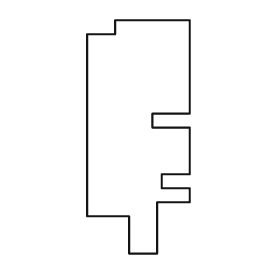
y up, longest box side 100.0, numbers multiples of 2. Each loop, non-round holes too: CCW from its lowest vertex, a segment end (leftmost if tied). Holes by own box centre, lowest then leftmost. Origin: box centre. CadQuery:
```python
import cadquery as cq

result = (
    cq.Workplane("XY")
    .moveTo(-4.0, -50.0)
    .lineTo(8.0, -50.0)
    .lineTo(8.0, -28.0)
    .lineTo(22.0, -28.0)
    .lineTo(22.0, -22.0)
    .lineTo(10.0, -22.0)
    .lineTo(10.0, -16.0)
    .lineTo(22.0, -16.0)
    .lineTo(22.0, 4.0)
    .lineTo(6.0, 4.0)
    .lineTo(6.0, 10.0)
    .lineTo(22.0, 10.0)
    .lineTo(22.0, 50.0)
    .lineTo(-10.0, 50.0)
    .lineTo(-10.0, 44.0)
    .lineTo(-22.0, 44.0)
    .lineTo(-22.0, -34.0)
    .lineTo(-4.0, -34.0)
    .close()
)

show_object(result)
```